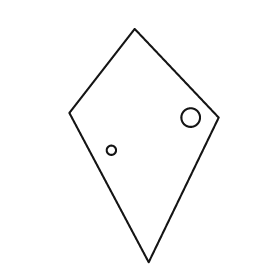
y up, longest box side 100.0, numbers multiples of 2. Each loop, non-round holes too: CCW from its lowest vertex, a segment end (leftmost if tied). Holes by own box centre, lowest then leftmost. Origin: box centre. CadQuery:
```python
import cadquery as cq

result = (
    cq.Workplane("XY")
    .moveTo(2.0, -50.0)
    .lineTo(32.0, 12.0)
    .lineTo(-4.0, 50.0)
    .lineTo(-32.0, 14.0)
    .close()
    .moveTo(-14.0, -2.0)
    .circle(2.0)
    .moveTo(20.0, 12.0)
    .circle(4.0)
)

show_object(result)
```